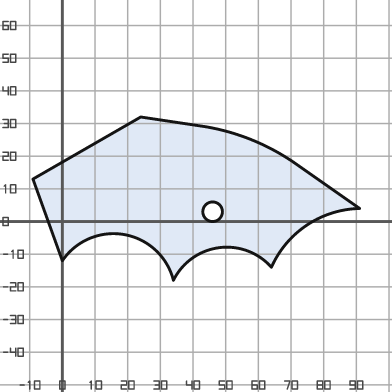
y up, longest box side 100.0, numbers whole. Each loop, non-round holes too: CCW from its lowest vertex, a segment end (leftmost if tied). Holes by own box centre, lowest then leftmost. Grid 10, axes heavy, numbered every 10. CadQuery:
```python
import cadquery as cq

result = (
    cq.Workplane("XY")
    .moveTo(34.0, -18.0)
    .threePointArc((48.0, -8.0), (64.0, -14.0))
    .threePointArc((75.0, -1.0), (91.0, 4.0))
    .lineTo(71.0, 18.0)
    .threePointArc((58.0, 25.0), (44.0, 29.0))
    .lineTo(24.0, 32.0)
    .lineTo(-9.0, 13.0)
    .lineTo(0.0, -12.0)
    .threePointArc((19.0, -4.0), (34.0, -18.0))
    .close()
    .moveTo(46.0, 3.0)
    .circle(3.0)
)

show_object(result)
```